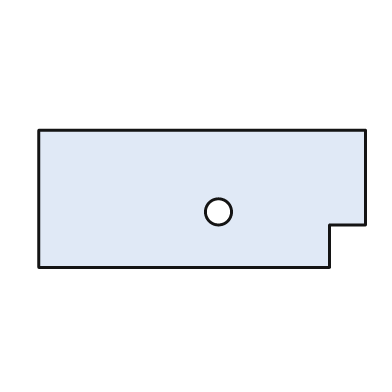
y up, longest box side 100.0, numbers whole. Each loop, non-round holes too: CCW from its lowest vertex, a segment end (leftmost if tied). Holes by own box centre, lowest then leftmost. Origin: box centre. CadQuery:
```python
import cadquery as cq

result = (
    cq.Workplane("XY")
    .moveTo(-50.0, -21.0)
    .lineTo(39.0, -21.0)
    .lineTo(39.0, -8.0)
    .lineTo(50.0, -8.0)
    .lineTo(50.0, 21.0)
    .lineTo(-50.0, 21.0)
    .close()
    .moveTo(5.0, -4.0)
    .circle(4.0)
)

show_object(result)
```